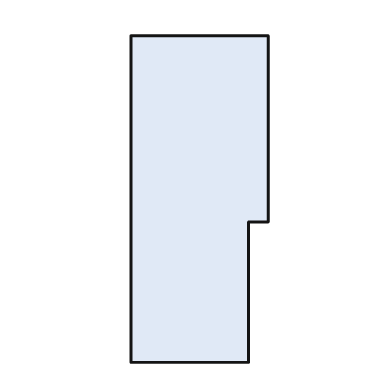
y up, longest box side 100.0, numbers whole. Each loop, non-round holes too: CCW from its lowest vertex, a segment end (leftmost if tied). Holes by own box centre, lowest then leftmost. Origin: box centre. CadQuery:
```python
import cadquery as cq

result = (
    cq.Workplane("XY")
    .moveTo(-21.0, -50.0)
    .lineTo(15.0, -50.0)
    .lineTo(15.0, -7.0)
    .lineTo(21.0, -7.0)
    .lineTo(21.0, 50.0)
    .lineTo(-21.0, 50.0)
    .close()
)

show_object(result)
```